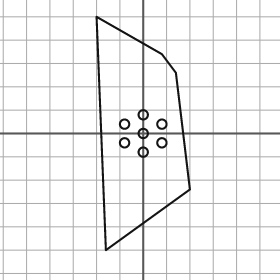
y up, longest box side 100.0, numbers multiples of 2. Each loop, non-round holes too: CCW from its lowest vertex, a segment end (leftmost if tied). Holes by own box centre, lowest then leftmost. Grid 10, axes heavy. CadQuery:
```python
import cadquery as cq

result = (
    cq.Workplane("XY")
    .moveTo(-16.0, -50.0)
    .lineTo(20.0, -24.0)
    .lineTo(14.0, 26.0)
    .lineTo(8.0, 34.0)
    .lineTo(-20.0, 50.0)
    .close()
    .moveTo(0.0, -8.0)
    .circle(2.0)
    .moveTo(-8.0, -4.0)
    .circle(2.0)
    .moveTo(8.0, -4.0)
    .circle(2.0)
    .moveTo(0.0, 0.0)
    .circle(2.0)
    .moveTo(-8.0, 4.0)
    .circle(2.0)
    .moveTo(8.0, 4.0)
    .circle(2.0)
    .moveTo(0.0, 8.0)
    .circle(2.0)
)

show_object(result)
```